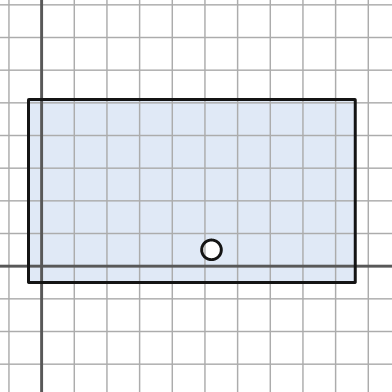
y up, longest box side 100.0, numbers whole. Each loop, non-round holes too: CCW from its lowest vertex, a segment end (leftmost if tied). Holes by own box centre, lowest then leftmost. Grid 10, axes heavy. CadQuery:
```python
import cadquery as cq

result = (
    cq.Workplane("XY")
    .moveTo(-4.0, -5.0)
    .lineTo(96.0, -5.0)
    .lineTo(96.0, 51.0)
    .lineTo(-4.0, 51.0)
    .close()
    .moveTo(52.0, 5.0)
    .circle(3.0)
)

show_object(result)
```